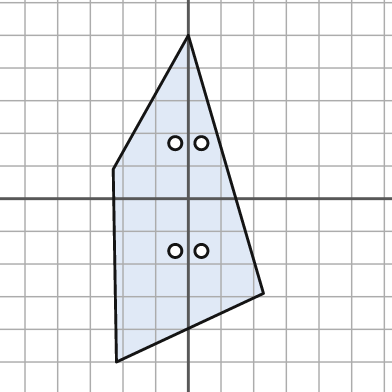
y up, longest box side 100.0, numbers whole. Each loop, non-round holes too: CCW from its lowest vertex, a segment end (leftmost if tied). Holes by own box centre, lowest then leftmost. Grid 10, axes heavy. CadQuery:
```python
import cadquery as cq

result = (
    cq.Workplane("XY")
    .moveTo(-22.0, -50.0)
    .lineTo(23.0, -29.0)
    .lineTo(0.0, 50.0)
    .lineTo(-23.0, 9.0)
    .close()
    .moveTo(-4.0, -16.0)
    .circle(2.0)
    .moveTo(4.0, -16.0)
    .circle(2.0)
    .moveTo(-4.0, 17.0)
    .circle(2.0)
    .moveTo(4.0, 17.0)
    .circle(2.0)
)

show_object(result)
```